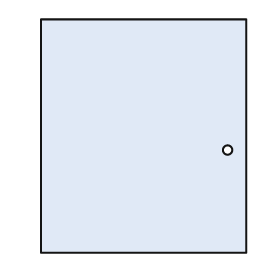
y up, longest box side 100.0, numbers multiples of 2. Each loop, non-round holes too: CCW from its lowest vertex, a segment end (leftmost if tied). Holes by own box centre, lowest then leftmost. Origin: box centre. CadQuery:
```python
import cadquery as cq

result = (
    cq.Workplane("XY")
    .moveTo(-44.0, -50.0)
    .lineTo(44.0, -50.0)
    .lineTo(44.0, 50.0)
    .lineTo(-44.0, 50.0)
    .close()
    .moveTo(36.0, -6.0)
    .circle(2.0)
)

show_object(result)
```